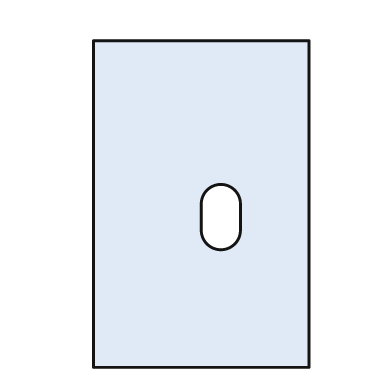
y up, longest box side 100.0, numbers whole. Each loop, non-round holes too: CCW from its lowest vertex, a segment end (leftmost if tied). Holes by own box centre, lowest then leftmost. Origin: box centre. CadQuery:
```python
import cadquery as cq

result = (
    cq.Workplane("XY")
    .moveTo(-33.0, -50.0)
    .lineTo(33.0, -50.0)
    .lineTo(33.0, 50.0)
    .lineTo(-33.0, 50.0)
    .close()
    .moveTo(0.0, -8.0)
    .threePointArc((6.0, -14.0), (12.0, -8.0))
    .lineTo(12.0, 0.0)
    .threePointArc((6.0, 6.0), (0.0, 0.0))
    .close()
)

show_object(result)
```